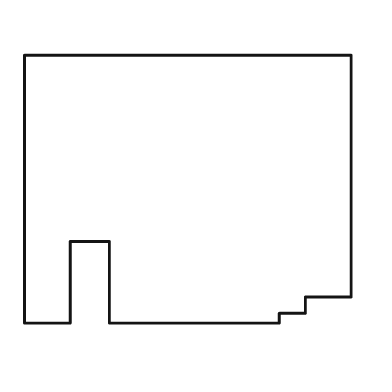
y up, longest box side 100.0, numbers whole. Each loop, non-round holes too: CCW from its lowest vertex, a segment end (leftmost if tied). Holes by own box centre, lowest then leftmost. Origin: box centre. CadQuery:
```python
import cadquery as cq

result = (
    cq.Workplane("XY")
    .moveTo(-50.0, -41.0)
    .lineTo(-36.0, -41.0)
    .lineTo(-36.0, -16.0)
    .lineTo(-24.0, -16.0)
    .lineTo(-24.0, -41.0)
    .lineTo(28.0, -41.0)
    .lineTo(28.0, -38.0)
    .lineTo(36.0, -38.0)
    .lineTo(36.0, -33.0)
    .lineTo(50.0, -33.0)
    .lineTo(50.0, 41.0)
    .lineTo(-50.0, 41.0)
    .close()
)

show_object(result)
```